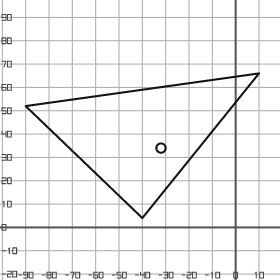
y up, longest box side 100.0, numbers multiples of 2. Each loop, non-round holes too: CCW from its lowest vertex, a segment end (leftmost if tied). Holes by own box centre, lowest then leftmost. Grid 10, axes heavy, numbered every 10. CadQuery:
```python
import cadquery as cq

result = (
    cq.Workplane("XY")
    .moveTo(-40.0, 4.0)
    .lineTo(10.0, 66.0)
    .lineTo(-90.0, 52.0)
    .close()
    .moveTo(-32.0, 34.0)
    .circle(2.0)
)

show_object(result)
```